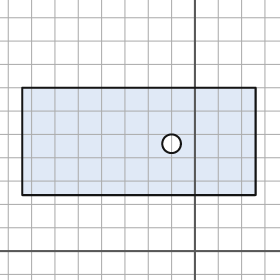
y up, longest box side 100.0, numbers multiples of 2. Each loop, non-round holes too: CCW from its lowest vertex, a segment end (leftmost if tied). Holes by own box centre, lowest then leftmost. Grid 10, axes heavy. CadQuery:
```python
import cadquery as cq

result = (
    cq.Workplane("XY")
    .moveTo(-74.0, 24.0)
    .lineTo(26.0, 24.0)
    .lineTo(26.0, 70.0)
    .lineTo(-74.0, 70.0)
    .close()
    .moveTo(-10.0, 46.0)
    .circle(4.0)
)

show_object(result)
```